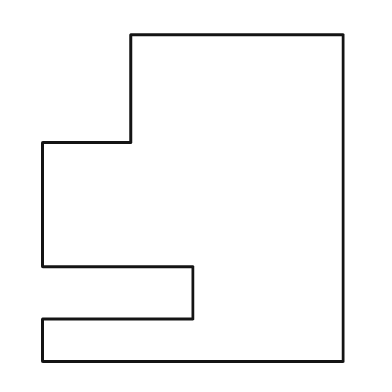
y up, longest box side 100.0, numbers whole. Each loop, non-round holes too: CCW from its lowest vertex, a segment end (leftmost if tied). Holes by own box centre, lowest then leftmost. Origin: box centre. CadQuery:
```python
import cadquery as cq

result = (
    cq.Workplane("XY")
    .moveTo(-46.0, -50.0)
    .lineTo(46.0, -50.0)
    .lineTo(46.0, 50.0)
    .lineTo(-19.0, 50.0)
    .lineTo(-19.0, 17.0)
    .lineTo(-46.0, 17.0)
    .lineTo(-46.0, -21.0)
    .lineTo(0.0, -21.0)
    .lineTo(0.0, -37.0)
    .lineTo(-46.0, -37.0)
    .close()
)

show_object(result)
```